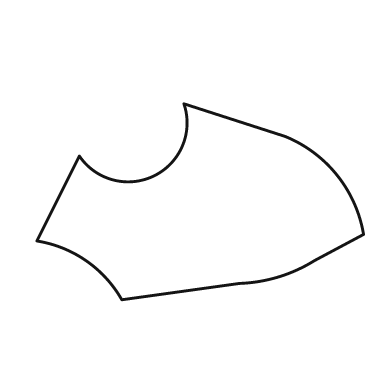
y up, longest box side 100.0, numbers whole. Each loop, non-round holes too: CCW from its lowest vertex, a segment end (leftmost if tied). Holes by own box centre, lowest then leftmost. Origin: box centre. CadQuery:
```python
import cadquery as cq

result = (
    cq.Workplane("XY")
    .moveTo(-24.0, -30.0)
    .lineTo(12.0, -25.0)
    .threePointArc((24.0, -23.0), (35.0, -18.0))
    .lineTo(50.0, -10.0)
    .threePointArc((42.0, 8.0), (26.0, 20.0))
    .lineTo(-5.0, 30.0)
    .threePointArc((-14.0, 8.0), (-37.0, 14.0))
    .lineTo(-50.0, -12.0)
    .threePointArc((-35.0, -18.0), (-24.0, -30.0))
    .close()
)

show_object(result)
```